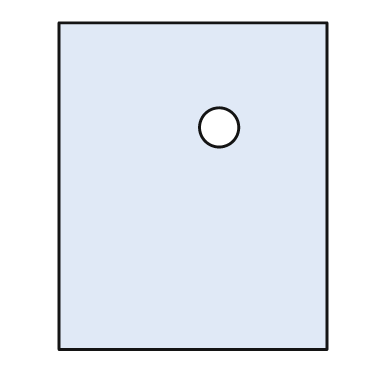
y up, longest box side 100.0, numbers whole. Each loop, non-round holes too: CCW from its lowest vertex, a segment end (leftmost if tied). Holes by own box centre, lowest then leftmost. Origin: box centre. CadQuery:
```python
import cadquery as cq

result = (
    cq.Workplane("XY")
    .moveTo(-41.0, -50.0)
    .lineTo(41.0, -50.0)
    .lineTo(41.0, 50.0)
    .lineTo(-41.0, 50.0)
    .close()
    .moveTo(8.0, 18.0)
    .circle(6.0)
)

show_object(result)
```